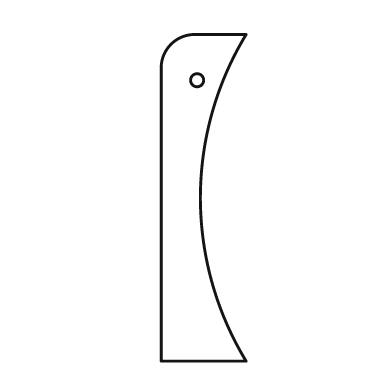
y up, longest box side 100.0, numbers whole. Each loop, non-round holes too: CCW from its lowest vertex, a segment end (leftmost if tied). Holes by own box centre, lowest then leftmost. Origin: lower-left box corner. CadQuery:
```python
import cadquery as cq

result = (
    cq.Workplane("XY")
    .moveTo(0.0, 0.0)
    .lineTo(26.0, 0.0)
    .threePointArc((12.0, 50.0), (26.0, 100.0))
    .lineTo(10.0, 100.0)
    .threePointArc((3.0, 97.0), (0.0, 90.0))
    .close()
    .moveTo(11.0, 86.0)
    .circle(2.0)
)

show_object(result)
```